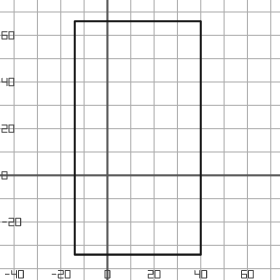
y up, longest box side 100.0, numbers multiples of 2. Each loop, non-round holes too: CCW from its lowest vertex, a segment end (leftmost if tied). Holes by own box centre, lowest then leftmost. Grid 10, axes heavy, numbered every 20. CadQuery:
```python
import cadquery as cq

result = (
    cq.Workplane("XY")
    .moveTo(-14.0, -34.0)
    .lineTo(40.0, -34.0)
    .lineTo(40.0, 66.0)
    .lineTo(-14.0, 66.0)
    .close()
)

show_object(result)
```